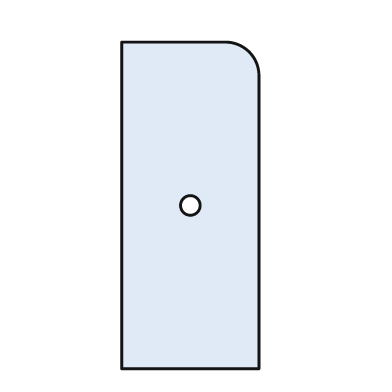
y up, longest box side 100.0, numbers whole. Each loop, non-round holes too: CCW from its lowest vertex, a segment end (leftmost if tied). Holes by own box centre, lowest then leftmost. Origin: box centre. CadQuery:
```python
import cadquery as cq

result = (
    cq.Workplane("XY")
    .moveTo(-21.0, -50.0)
    .lineTo(21.0, -50.0)
    .lineTo(21.0, 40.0)
    .threePointArc((18.0, 47.0), (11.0, 50.0))
    .lineTo(-21.0, 50.0)
    .close()
    .moveTo(0.0, 0.0)
    .circle(3.0)
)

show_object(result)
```